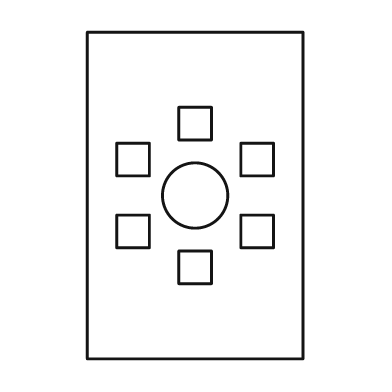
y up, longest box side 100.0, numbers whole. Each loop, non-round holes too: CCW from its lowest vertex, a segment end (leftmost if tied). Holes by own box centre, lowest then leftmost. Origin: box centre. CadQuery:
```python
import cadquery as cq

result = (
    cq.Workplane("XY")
    .moveTo(-33.0, -50.0)
    .lineTo(33.0, -50.0)
    .lineTo(33.0, 50.0)
    .lineTo(-33.0, 50.0)
    .close()
    .moveTo(-5.0, -27.0)
    .lineTo(5.0, -27.0)
    .lineTo(5.0, -17.0)
    .lineTo(-5.0, -17.0)
    .close()
    .moveTo(-24.0, -16.0)
    .lineTo(-14.0, -16.0)
    .lineTo(-14.0, -6.0)
    .lineTo(-24.0, -6.0)
    .close()
    .moveTo(14.0, -16.0)
    .lineTo(24.0, -16.0)
    .lineTo(24.0, -6.0)
    .lineTo(14.0, -6.0)
    .close()
    .moveTo(0.0, 0.0)
    .circle(10.0)
    .moveTo(-24.0, 6.0)
    .lineTo(-14.0, 6.0)
    .lineTo(-14.0, 16.0)
    .lineTo(-24.0, 16.0)
    .close()
    .moveTo(14.0, 6.0)
    .lineTo(24.0, 6.0)
    .lineTo(24.0, 16.0)
    .lineTo(14.0, 16.0)
    .close()
    .moveTo(-5.0, 17.0)
    .lineTo(5.0, 17.0)
    .lineTo(5.0, 27.0)
    .lineTo(-5.0, 27.0)
    .close()
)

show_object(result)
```